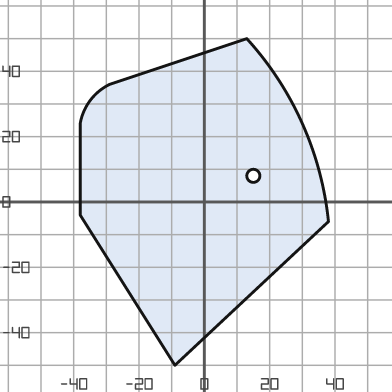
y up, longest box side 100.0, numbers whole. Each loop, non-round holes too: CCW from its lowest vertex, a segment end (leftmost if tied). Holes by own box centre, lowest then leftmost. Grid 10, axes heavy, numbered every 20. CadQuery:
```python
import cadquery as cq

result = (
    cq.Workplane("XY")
    .moveTo(-9.0, -50.0)
    .lineTo(38.0, -6.0)
    .threePointArc((30.0, 24.0), (13.0, 50.0))
    .lineTo(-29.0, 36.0)
    .threePointArc((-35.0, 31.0), (-38.0, 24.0))
    .lineTo(-38.0, -4.0)
    .close()
    .moveTo(15.0, 8.0)
    .circle(2.0)
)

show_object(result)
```